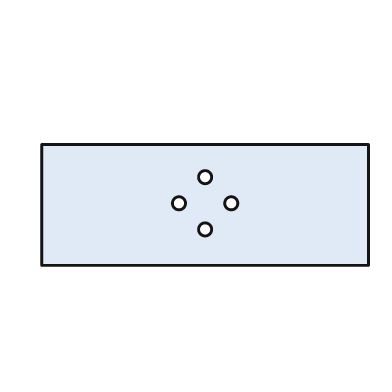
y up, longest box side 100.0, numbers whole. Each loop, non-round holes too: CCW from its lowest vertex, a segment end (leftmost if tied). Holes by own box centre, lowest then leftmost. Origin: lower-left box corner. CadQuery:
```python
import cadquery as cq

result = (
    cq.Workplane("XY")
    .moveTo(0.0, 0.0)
    .lineTo(100.0, 0.0)
    .lineTo(100.0, 37.0)
    .lineTo(0.0, 37.0)
    .close()
    .moveTo(50.0, 11.0)
    .circle(2.0)
    .moveTo(42.0, 19.0)
    .circle(2.0)
    .moveTo(58.0, 19.0)
    .circle(2.0)
    .moveTo(50.0, 27.0)
    .circle(2.0)
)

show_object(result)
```